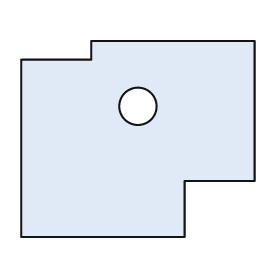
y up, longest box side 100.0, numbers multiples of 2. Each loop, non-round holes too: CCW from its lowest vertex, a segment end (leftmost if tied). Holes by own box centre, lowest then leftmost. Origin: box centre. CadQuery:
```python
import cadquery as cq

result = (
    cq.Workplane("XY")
    .moveTo(-50.0, -42.0)
    .lineTo(20.0, -42.0)
    .lineTo(20.0, -18.0)
    .lineTo(50.0, -18.0)
    .lineTo(50.0, 42.0)
    .lineTo(-20.0, 42.0)
    .lineTo(-20.0, 34.0)
    .lineTo(-50.0, 34.0)
    .close()
    .moveTo(0.0, 14.0)
    .circle(8.0)
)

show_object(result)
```